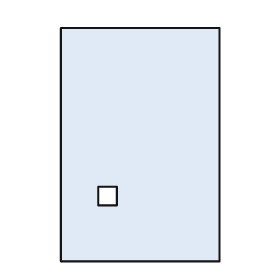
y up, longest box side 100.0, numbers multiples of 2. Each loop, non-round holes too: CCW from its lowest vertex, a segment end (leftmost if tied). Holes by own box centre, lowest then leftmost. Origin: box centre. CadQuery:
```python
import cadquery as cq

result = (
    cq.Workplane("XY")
    .moveTo(-34.0, -50.0)
    .lineTo(34.0, -50.0)
    .lineTo(34.0, 50.0)
    .lineTo(-34.0, 50.0)
    .close()
    .moveTo(-18.0, -26.0)
    .lineTo(-10.0, -26.0)
    .lineTo(-10.0, -18.0)
    .lineTo(-18.0, -18.0)
    .close()
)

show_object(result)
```